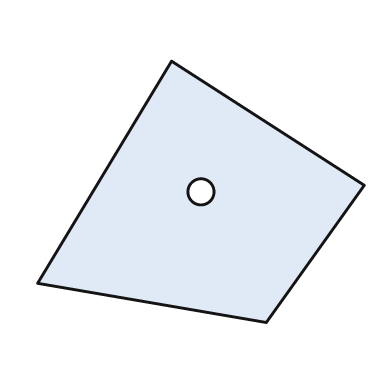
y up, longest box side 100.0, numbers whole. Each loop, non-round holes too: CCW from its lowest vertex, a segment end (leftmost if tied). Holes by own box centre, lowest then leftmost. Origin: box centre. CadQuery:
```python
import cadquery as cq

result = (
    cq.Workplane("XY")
    .moveTo(20.0, -40.0)
    .lineTo(50.0, 2.0)
    .lineTo(-9.0, 40.0)
    .lineTo(-50.0, -28.0)
    .close()
    .moveTo(0.0, 0.0)
    .circle(4.0)
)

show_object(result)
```